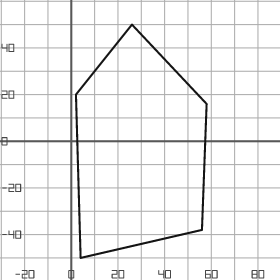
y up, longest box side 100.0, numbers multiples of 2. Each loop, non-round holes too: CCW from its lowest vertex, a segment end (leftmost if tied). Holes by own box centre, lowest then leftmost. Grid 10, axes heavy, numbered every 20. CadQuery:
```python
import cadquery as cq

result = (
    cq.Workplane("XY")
    .moveTo(4.0, -50.0)
    .lineTo(56.0, -38.0)
    .lineTo(58.0, 16.0)
    .lineTo(26.0, 50.0)
    .lineTo(2.0, 20.0)
    .close()
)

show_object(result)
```